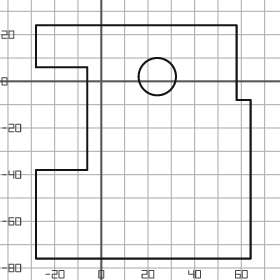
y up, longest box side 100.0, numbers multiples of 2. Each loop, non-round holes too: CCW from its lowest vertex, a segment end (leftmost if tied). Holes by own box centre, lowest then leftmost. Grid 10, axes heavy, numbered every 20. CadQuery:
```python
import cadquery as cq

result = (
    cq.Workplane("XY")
    .moveTo(-28.0, -76.0)
    .lineTo(64.0, -76.0)
    .lineTo(64.0, -8.0)
    .lineTo(58.0, -8.0)
    .lineTo(58.0, 24.0)
    .lineTo(-28.0, 24.0)
    .lineTo(-28.0, 6.0)
    .lineTo(-6.0, 6.0)
    .lineTo(-6.0, -38.0)
    .lineTo(-28.0, -38.0)
    .close()
    .moveTo(24.0, 2.0)
    .circle(8.0)
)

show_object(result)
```